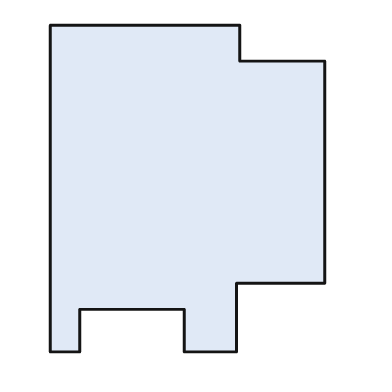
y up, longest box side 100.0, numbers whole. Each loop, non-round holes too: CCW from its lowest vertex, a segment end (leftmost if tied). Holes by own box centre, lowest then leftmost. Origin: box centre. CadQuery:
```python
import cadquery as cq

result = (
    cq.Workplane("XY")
    .moveTo(-42.0, -50.0)
    .lineTo(-33.0, -50.0)
    .lineTo(-33.0, -37.0)
    .lineTo(-1.0, -37.0)
    .lineTo(-1.0, -50.0)
    .lineTo(15.0, -50.0)
    .lineTo(15.0, -29.0)
    .lineTo(42.0, -29.0)
    .lineTo(42.0, 39.0)
    .lineTo(16.0, 39.0)
    .lineTo(16.0, 50.0)
    .lineTo(-42.0, 50.0)
    .close()
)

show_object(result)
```